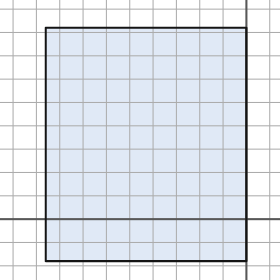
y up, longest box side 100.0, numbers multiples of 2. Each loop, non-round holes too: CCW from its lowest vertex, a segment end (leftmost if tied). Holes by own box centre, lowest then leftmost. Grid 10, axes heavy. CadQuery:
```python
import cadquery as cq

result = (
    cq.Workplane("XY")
    .moveTo(-86.0, -18.0)
    .lineTo(0.0, -18.0)
    .lineTo(0.0, 82.0)
    .lineTo(-86.0, 82.0)
    .close()
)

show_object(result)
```